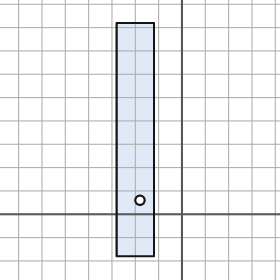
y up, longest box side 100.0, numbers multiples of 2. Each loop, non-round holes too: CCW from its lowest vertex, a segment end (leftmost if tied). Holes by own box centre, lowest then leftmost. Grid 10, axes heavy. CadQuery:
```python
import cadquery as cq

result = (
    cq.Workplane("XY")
    .moveTo(-28.0, -18.0)
    .lineTo(-12.0, -18.0)
    .lineTo(-12.0, 82.0)
    .lineTo(-28.0, 82.0)
    .close()
    .moveTo(-18.0, 6.0)
    .circle(2.0)
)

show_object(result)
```